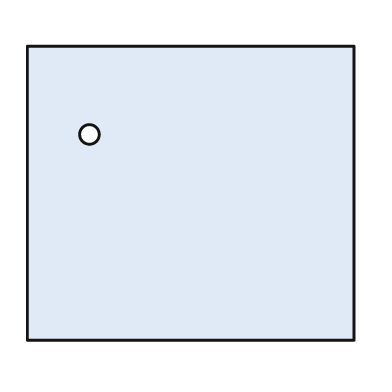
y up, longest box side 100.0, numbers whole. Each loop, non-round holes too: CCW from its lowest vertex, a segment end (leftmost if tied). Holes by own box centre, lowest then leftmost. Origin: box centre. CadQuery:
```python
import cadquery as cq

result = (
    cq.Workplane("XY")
    .moveTo(-50.0, -45.0)
    .lineTo(50.0, -45.0)
    .lineTo(50.0, 45.0)
    .lineTo(-50.0, 45.0)
    .close()
    .moveTo(-31.0, 18.0)
    .circle(3.0)
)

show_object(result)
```